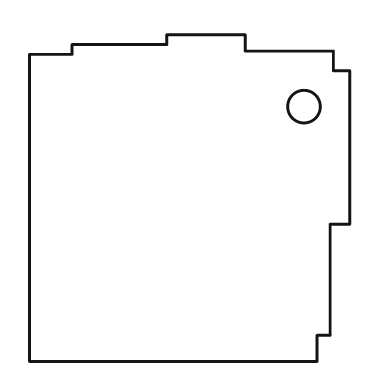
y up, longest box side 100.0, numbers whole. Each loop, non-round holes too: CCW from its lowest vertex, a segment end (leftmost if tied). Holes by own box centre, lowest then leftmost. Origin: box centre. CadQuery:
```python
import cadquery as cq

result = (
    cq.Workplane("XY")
    .moveTo(-49.0, -50.0)
    .lineTo(39.0, -50.0)
    .lineTo(39.0, -42.0)
    .lineTo(43.0, -42.0)
    .lineTo(43.0, -8.0)
    .lineTo(49.0, -8.0)
    .lineTo(49.0, 39.0)
    .lineTo(44.0, 39.0)
    .lineTo(44.0, 45.0)
    .lineTo(17.0, 45.0)
    .lineTo(17.0, 50.0)
    .lineTo(-7.0, 50.0)
    .lineTo(-7.0, 47.0)
    .lineTo(-36.0, 47.0)
    .lineTo(-36.0, 44.0)
    .lineTo(-49.0, 44.0)
    .close()
    .moveTo(35.0, 28.0)
    .circle(5.0)
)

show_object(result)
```